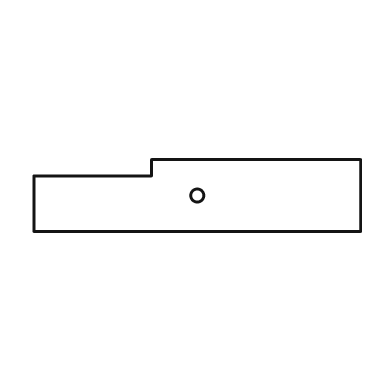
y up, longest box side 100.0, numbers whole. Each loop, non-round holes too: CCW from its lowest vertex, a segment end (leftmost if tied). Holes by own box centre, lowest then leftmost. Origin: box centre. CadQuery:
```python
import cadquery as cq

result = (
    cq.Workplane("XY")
    .moveTo(-50.0, -11.0)
    .lineTo(50.0, -11.0)
    .lineTo(50.0, 11.0)
    .lineTo(-14.0, 11.0)
    .lineTo(-14.0, 6.0)
    .lineTo(-50.0, 6.0)
    .close()
    .moveTo(0.0, 0.0)
    .circle(2.0)
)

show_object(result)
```